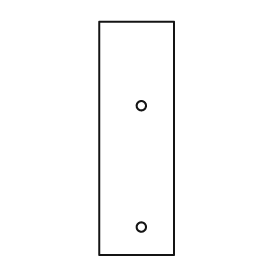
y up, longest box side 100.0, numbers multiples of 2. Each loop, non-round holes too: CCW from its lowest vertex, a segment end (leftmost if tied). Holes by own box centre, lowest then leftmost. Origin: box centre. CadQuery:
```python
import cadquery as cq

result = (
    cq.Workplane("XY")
    .moveTo(-16.0, -50.0)
    .lineTo(16.0, -50.0)
    .lineTo(16.0, 50.0)
    .lineTo(-16.0, 50.0)
    .close()
    .moveTo(2.0, -38.0)
    .circle(2.0)
    .moveTo(2.0, 14.0)
    .circle(2.0)
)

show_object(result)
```